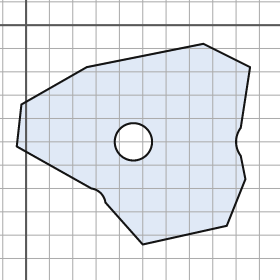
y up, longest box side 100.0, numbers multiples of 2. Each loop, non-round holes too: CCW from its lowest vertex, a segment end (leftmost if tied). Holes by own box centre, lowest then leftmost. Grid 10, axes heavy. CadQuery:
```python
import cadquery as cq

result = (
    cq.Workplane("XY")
    .moveTo(50.0, -94.0)
    .lineTo(86.0, -86.0)
    .lineTo(94.0, -66.0)
    .lineTo(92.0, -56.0)
    .threePointArc((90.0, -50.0), (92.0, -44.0))
    .lineTo(96.0, -18.0)
    .lineTo(76.0, -8.0)
    .lineTo(26.0, -18.0)
    .lineTo(-2.0, -34.0)
    .lineTo(-4.0, -52.0)
    .lineTo(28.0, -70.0)
    .threePointArc((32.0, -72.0), (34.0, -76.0))
    .close()
    .moveTo(46.0, -50.0)
    .circle(8.0)
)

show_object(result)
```